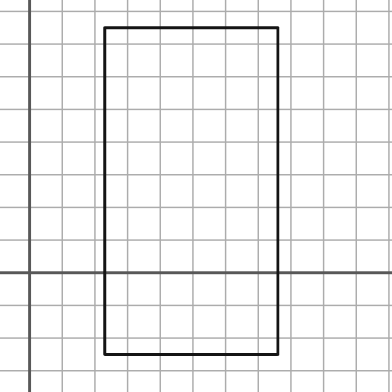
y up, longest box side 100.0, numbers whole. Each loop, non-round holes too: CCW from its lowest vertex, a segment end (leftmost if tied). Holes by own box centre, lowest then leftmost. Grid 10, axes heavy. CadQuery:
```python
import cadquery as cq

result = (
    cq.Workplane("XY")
    .moveTo(23.0, -25.0)
    .lineTo(76.0, -25.0)
    .lineTo(76.0, 75.0)
    .lineTo(23.0, 75.0)
    .close()
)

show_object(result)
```